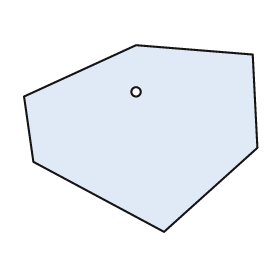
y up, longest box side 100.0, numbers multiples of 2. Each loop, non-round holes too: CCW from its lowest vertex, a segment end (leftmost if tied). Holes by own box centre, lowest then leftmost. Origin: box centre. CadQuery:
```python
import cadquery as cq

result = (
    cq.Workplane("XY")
    .moveTo(10.0, -40.0)
    .lineTo(50.0, -4.0)
    .lineTo(48.0, 36.0)
    .lineTo(-2.0, 40.0)
    .lineTo(-50.0, 18.0)
    .lineTo(-46.0, -10.0)
    .close()
    .moveTo(-2.0, 20.0)
    .circle(2.0)
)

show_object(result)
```